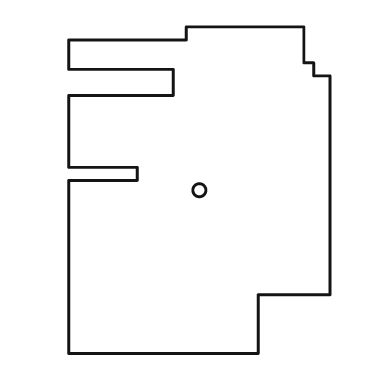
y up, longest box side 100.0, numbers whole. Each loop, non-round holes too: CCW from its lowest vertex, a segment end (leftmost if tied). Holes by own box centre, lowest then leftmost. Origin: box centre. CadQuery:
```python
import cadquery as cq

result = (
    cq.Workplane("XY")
    .moveTo(-40.0, -50.0)
    .lineTo(18.0, -50.0)
    .lineTo(18.0, -32.0)
    .lineTo(40.0, -32.0)
    .lineTo(40.0, 35.0)
    .lineTo(35.0, 35.0)
    .lineTo(35.0, 39.0)
    .lineTo(32.0, 39.0)
    .lineTo(32.0, 50.0)
    .lineTo(-4.0, 50.0)
    .lineTo(-4.0, 46.0)
    .lineTo(-40.0, 46.0)
    .lineTo(-40.0, 37.0)
    .lineTo(-8.0, 37.0)
    .lineTo(-8.0, 29.0)
    .lineTo(-40.0, 29.0)
    .lineTo(-40.0, 7.0)
    .lineTo(-19.0, 7.0)
    .lineTo(-19.0, 3.0)
    .lineTo(-40.0, 3.0)
    .close()
    .moveTo(0.0, 0.0)
    .circle(2.0)
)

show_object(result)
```